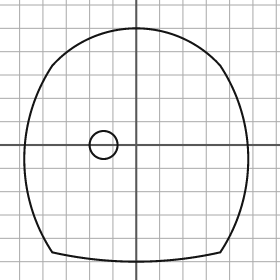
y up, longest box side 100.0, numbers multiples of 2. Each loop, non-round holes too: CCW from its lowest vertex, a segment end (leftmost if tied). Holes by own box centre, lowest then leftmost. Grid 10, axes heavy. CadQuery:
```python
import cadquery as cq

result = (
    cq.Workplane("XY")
    .moveTo(-36.0, -46.0)
    .threePointArc((0.0, -50.0), (36.0, -46.0))
    .threePointArc((48.0, -6.0), (36.0, 34.0))
    .threePointArc((0.0, 50.0), (-36.0, 34.0))
    .threePointArc((-48.0, -6.0), (-36.0, -46.0))
    .close()
    .moveTo(-14.0, 0.0)
    .circle(6.0)
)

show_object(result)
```